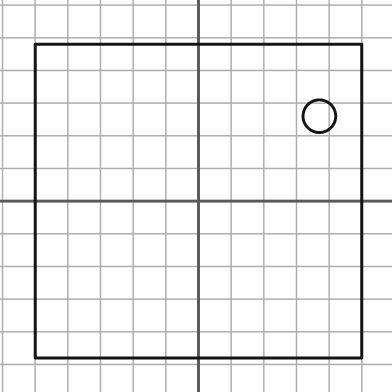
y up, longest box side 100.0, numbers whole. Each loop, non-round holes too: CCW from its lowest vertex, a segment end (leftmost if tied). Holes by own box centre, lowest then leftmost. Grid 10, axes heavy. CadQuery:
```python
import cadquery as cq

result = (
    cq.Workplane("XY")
    .moveTo(-50.0, -48.0)
    .lineTo(50.0, -48.0)
    .lineTo(50.0, 48.0)
    .lineTo(-50.0, 48.0)
    .close()
    .moveTo(37.0, 26.0)
    .circle(5.0)
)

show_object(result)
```